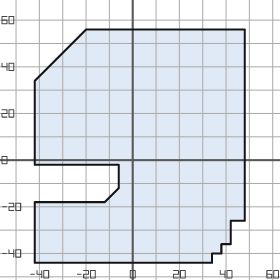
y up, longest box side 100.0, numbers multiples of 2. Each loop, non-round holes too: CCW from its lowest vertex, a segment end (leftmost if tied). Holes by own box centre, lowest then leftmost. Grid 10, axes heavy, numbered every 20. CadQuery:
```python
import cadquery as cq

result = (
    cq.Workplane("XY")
    .moveTo(-42.0, -44.0)
    .lineTo(34.0, -44.0)
    .lineTo(34.0, -40.0)
    .lineTo(38.0, -40.0)
    .lineTo(38.0, -36.0)
    .lineTo(42.0, -36.0)
    .lineTo(42.0, -26.0)
    .lineTo(48.0, -26.0)
    .lineTo(48.0, 56.0)
    .lineTo(-20.0, 56.0)
    .lineTo(-42.0, 34.0)
    .lineTo(-42.0, -2.0)
    .lineTo(-6.0, -2.0)
    .lineTo(-6.0, -12.0)
    .lineTo(-12.0, -18.0)
    .lineTo(-42.0, -18.0)
    .close()
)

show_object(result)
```